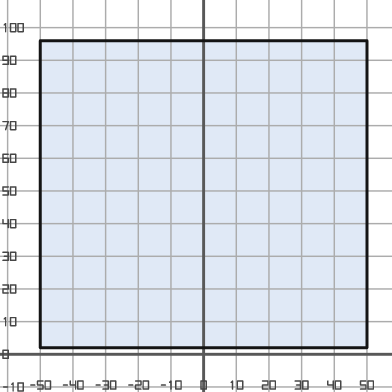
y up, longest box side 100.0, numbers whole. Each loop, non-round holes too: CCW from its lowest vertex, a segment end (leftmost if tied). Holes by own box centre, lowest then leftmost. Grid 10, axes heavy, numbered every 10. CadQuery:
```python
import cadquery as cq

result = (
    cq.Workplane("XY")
    .moveTo(-50.0, 2.0)
    .lineTo(50.0, 2.0)
    .lineTo(50.0, 96.0)
    .lineTo(-50.0, 96.0)
    .close()
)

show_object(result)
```